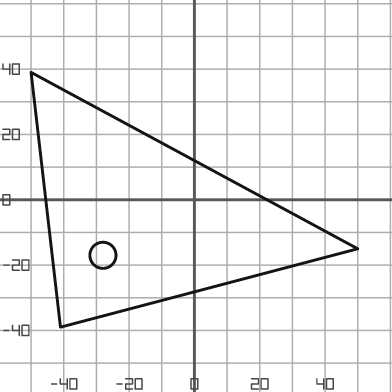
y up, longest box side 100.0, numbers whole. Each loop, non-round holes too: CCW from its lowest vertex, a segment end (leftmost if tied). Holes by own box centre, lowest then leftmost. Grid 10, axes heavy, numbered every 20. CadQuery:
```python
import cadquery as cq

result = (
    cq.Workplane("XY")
    .moveTo(-41.0, -39.0)
    .lineTo(50.0, -15.0)
    .lineTo(-50.0, 39.0)
    .close()
    .moveTo(-28.0, -17.0)
    .circle(4.0)
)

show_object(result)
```